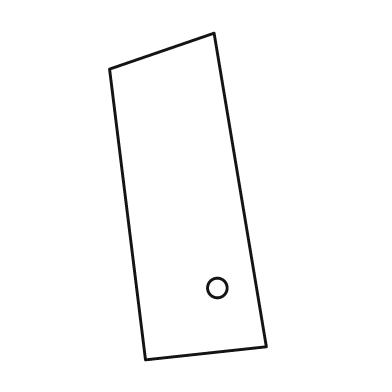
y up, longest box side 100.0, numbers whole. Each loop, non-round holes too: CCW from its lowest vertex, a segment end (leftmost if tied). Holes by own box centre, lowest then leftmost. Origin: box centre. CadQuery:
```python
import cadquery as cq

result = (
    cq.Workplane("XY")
    .moveTo(-13.0, -50.0)
    .lineTo(24.0, -46.0)
    .lineTo(8.0, 50.0)
    .lineTo(-24.0, 39.0)
    .close()
    .moveTo(9.0, -28.0)
    .circle(3.0)
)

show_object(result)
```